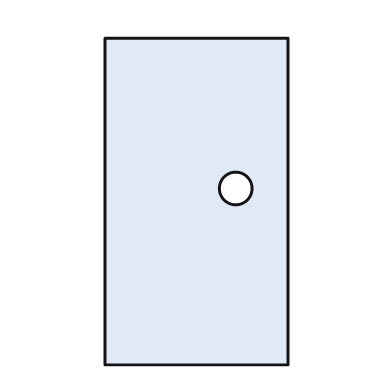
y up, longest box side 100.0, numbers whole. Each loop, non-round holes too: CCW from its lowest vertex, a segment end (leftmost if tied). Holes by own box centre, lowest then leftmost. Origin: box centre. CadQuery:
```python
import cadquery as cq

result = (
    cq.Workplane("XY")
    .moveTo(-28.0, -50.0)
    .lineTo(28.0, -50.0)
    .lineTo(28.0, 50.0)
    .lineTo(-28.0, 50.0)
    .close()
    .moveTo(12.0, 4.0)
    .circle(5.0)
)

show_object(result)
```